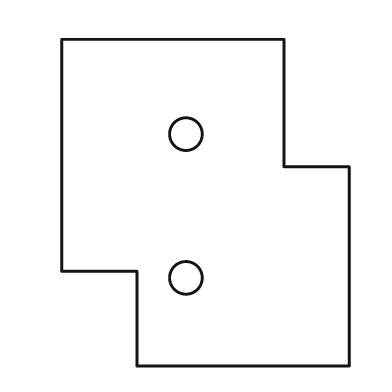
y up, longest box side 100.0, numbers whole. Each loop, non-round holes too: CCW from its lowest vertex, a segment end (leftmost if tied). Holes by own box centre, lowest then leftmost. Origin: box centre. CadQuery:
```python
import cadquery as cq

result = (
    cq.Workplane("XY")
    .moveTo(-21.0, -50.0)
    .lineTo(44.0, -50.0)
    .lineTo(44.0, 11.0)
    .lineTo(24.0, 11.0)
    .lineTo(24.0, 50.0)
    .lineTo(-44.0, 50.0)
    .lineTo(-44.0, -21.0)
    .lineTo(-21.0, -21.0)
    .close()
    .moveTo(-6.0, -23.0)
    .circle(5.0)
    .moveTo(-6.0, 21.0)
    .circle(5.0)
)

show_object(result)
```